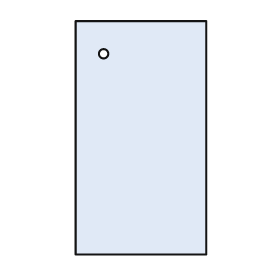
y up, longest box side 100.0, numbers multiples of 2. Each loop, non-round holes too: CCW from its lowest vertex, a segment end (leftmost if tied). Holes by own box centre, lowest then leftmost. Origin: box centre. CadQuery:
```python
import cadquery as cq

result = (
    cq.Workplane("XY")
    .moveTo(-28.0, -50.0)
    .lineTo(28.0, -50.0)
    .lineTo(28.0, 50.0)
    .lineTo(-28.0, 50.0)
    .close()
    .moveTo(-16.0, 36.0)
    .circle(2.0)
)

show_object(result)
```